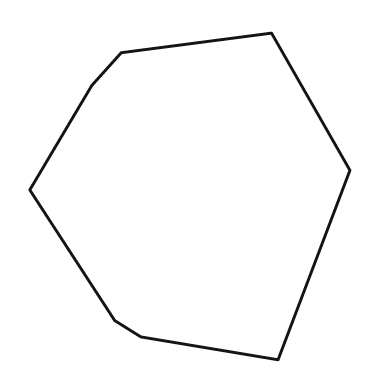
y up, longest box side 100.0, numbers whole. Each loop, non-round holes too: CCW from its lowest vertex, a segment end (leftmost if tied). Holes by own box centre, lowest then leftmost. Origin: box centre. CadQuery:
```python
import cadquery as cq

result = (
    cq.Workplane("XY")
    .moveTo(27.0, -50.0)
    .lineTo(49.0, 8.0)
    .lineTo(25.0, 50.0)
    .lineTo(-21.0, 44.0)
    .lineTo(-30.0, 34.0)
    .lineTo(-49.0, 2.0)
    .lineTo(-23.0, -38.0)
    .lineTo(-15.0, -43.0)
    .close()
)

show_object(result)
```